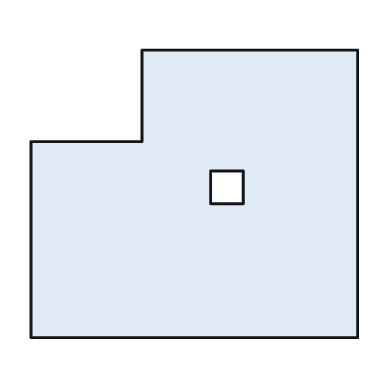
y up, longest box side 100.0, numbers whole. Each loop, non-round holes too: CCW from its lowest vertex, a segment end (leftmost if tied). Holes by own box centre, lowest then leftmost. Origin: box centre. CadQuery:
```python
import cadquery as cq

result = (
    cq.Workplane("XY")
    .moveTo(-50.0, -44.0)
    .lineTo(50.0, -44.0)
    .lineTo(50.0, 44.0)
    .lineTo(-16.0, 44.0)
    .lineTo(-16.0, 16.0)
    .lineTo(-50.0, 16.0)
    .close()
    .moveTo(5.0, -3.0)
    .lineTo(15.0, -3.0)
    .lineTo(15.0, 7.0)
    .lineTo(5.0, 7.0)
    .close()
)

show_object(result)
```